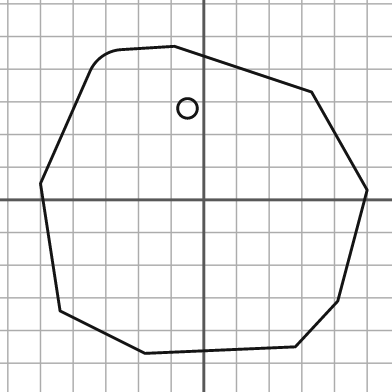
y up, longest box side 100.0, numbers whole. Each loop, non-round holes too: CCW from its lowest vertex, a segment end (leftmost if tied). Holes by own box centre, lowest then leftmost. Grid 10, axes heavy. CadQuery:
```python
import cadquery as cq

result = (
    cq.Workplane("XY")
    .moveTo(-18.0, -47.0)
    .lineTo(28.0, -45.0)
    .lineTo(41.0, -31.0)
    .lineTo(50.0, 3.0)
    .lineTo(33.0, 33.0)
    .lineTo(-9.0, 47.0)
    .lineTo(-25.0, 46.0)
    .threePointArc((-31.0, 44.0), (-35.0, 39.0))
    .lineTo(-50.0, 5.0)
    .lineTo(-44.0, -34.0)
    .close()
    .moveTo(-5.0, 28.0)
    .circle(3.0)
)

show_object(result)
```